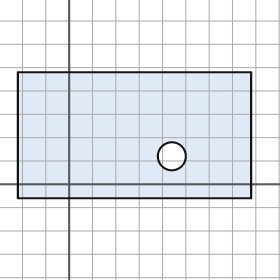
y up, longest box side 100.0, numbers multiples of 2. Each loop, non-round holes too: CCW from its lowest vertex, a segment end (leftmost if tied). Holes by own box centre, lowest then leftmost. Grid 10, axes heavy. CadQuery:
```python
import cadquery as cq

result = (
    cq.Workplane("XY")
    .moveTo(-22.0, -6.0)
    .lineTo(78.0, -6.0)
    .lineTo(78.0, 48.0)
    .lineTo(-22.0, 48.0)
    .close()
    .moveTo(44.0, 12.0)
    .circle(6.0)
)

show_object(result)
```